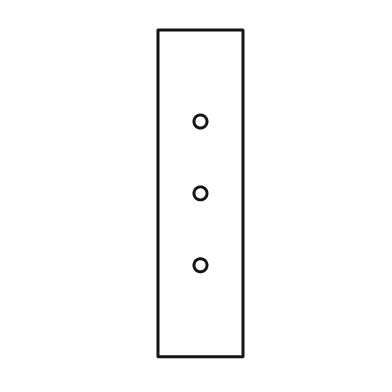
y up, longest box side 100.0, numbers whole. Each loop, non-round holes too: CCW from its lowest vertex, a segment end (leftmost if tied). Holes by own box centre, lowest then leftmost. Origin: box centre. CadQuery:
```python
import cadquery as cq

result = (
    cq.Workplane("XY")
    .moveTo(-13.0, -50.0)
    .lineTo(13.0, -50.0)
    .lineTo(13.0, 50.0)
    .lineTo(-13.0, 50.0)
    .close()
    .moveTo(0.0, -22.0)
    .circle(2.0)
    .moveTo(0.0, 0.0)
    .circle(2.0)
    .moveTo(0.0, 22.0)
    .circle(2.0)
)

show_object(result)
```